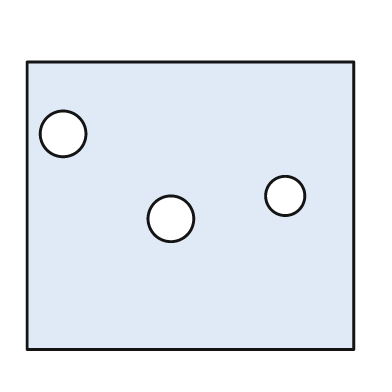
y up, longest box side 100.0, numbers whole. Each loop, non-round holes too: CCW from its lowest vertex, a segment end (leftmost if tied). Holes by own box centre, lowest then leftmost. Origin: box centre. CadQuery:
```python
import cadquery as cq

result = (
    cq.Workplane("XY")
    .moveTo(-50.0, -44.0)
    .lineTo(50.0, -44.0)
    .lineTo(50.0, 44.0)
    .lineTo(-50.0, 44.0)
    .close()
    .moveTo(-6.0, -4.0)
    .circle(7.0)
    .moveTo(29.0, 3.0)
    .circle(6.0)
    .moveTo(-39.0, 22.0)
    .circle(7.0)
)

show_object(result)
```